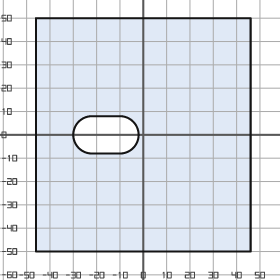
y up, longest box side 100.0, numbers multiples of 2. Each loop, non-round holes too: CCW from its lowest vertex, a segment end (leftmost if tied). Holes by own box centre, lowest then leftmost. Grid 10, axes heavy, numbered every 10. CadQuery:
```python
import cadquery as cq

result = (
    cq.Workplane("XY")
    .moveTo(-46.0, -50.0)
    .lineTo(46.0, -50.0)
    .lineTo(46.0, 50.0)
    .lineTo(-46.0, 50.0)
    .close()
    .moveTo(-22.0, -8.0)
    .lineTo(-10.0, -8.0)
    .threePointArc((-2.0, 0.0), (-10.0, 8.0))
    .lineTo(-22.0, 8.0)
    .threePointArc((-30.0, 0.0), (-22.0, -8.0))
    .close()
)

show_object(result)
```